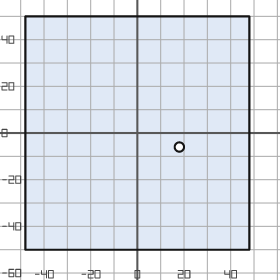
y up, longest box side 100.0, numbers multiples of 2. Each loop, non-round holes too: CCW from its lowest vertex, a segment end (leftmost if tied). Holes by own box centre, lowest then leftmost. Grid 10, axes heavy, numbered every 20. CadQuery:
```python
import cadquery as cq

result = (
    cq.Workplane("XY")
    .moveTo(-48.0, -50.0)
    .lineTo(48.0, -50.0)
    .lineTo(48.0, 50.0)
    .lineTo(-48.0, 50.0)
    .close()
    .moveTo(18.0, -6.0)
    .circle(2.0)
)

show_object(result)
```